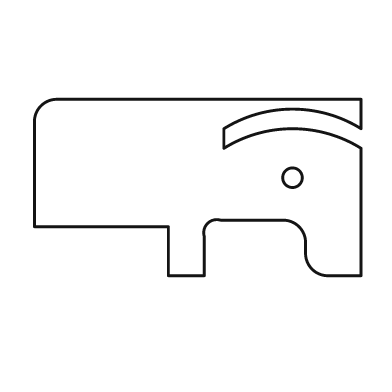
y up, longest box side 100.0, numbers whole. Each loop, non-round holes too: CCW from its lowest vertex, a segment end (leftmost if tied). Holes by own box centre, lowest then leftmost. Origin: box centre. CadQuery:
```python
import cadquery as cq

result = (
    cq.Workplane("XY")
    .moveTo(-9.0, -27.0)
    .lineTo(2.0, -27.0)
    .lineTo(2.0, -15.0)
    .threePointArc((3.0, -11.0), (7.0, -10.0))
    .lineTo(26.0, -10.0)
    .threePointArc((31.0, -12.0), (33.0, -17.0))
    .lineTo(33.0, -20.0)
    .threePointArc((35.0, -25.0), (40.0, -27.0))
    .lineTo(50.0, -27.0)
    .lineTo(50.0, 12.0)
    .threePointArc((29.0, 18.0), (8.0, 12.0))
    .lineTo(8.0, 18.0)
    .threePointArc((29.0, 24.0), (50.0, 18.0))
    .lineTo(50.0, 27.0)
    .lineTo(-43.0, 27.0)
    .threePointArc((-48.0, 25.0), (-50.0, 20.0))
    .lineTo(-50.0, -12.0)
    .lineTo(-9.0, -12.0)
    .close()
    .moveTo(29.0, 3.0)
    .circle(3.0)
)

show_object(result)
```